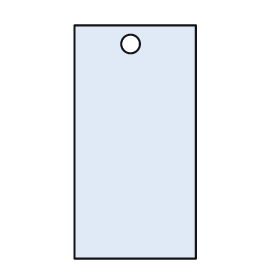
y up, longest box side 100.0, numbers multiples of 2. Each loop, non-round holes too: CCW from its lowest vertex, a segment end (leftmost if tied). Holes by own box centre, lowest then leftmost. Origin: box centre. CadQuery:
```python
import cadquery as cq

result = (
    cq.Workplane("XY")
    .moveTo(-26.0, -50.0)
    .lineTo(26.0, -50.0)
    .lineTo(26.0, 50.0)
    .lineTo(-26.0, 50.0)
    .close()
    .moveTo(-2.0, 42.0)
    .circle(4.0)
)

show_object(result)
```